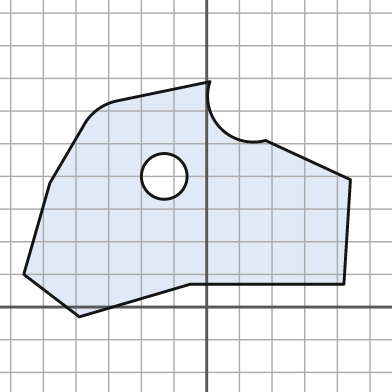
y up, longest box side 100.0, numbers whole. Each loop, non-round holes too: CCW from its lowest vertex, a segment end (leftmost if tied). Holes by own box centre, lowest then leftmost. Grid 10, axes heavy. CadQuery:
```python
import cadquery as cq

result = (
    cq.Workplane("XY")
    .moveTo(-39.0, -3.0)
    .lineTo(-5.0, 7.0)
    .lineTo(42.0, 7.0)
    .lineTo(44.0, 39.0)
    .lineTo(18.0, 51.0)
    .threePointArc((4.0, 55.0), (1.0, 69.0))
    .lineTo(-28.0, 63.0)
    .threePointArc((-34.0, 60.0), (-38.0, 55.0))
    .lineTo(-48.0, 38.0)
    .lineTo(-56.0, 10.0)
    .close()
    .moveTo(-13.0, 40.0)
    .circle(7.0)
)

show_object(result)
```